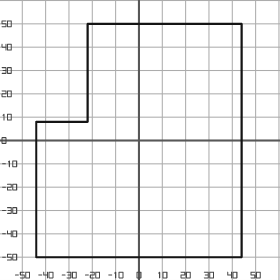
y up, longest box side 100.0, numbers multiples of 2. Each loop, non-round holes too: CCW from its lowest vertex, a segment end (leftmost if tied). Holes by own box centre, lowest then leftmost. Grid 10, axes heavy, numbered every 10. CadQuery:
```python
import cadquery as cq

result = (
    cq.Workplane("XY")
    .moveTo(-44.0, -50.0)
    .lineTo(44.0, -50.0)
    .lineTo(44.0, 50.0)
    .lineTo(-22.0, 50.0)
    .lineTo(-22.0, 8.0)
    .lineTo(-44.0, 8.0)
    .close()
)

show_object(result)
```